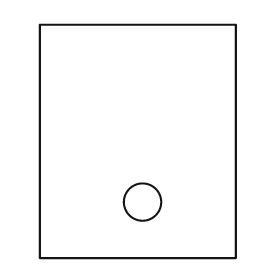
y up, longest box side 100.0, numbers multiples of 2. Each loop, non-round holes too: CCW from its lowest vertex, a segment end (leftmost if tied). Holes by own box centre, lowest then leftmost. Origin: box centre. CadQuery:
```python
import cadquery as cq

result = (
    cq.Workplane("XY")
    .moveTo(-42.0, -50.0)
    .lineTo(42.0, -50.0)
    .lineTo(42.0, 50.0)
    .lineTo(-42.0, 50.0)
    .close()
    .moveTo(2.0, -26.0)
    .circle(8.0)
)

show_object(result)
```